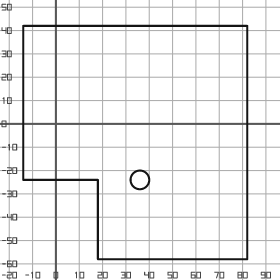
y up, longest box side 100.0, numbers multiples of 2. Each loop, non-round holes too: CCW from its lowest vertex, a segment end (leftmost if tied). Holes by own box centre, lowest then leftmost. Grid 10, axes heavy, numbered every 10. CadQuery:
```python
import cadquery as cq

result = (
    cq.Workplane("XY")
    .moveTo(18.0, -58.0)
    .lineTo(82.0, -58.0)
    .lineTo(82.0, 42.0)
    .lineTo(-14.0, 42.0)
    .lineTo(-14.0, -24.0)
    .lineTo(18.0, -24.0)
    .close()
    .moveTo(36.0, -24.0)
    .circle(4.0)
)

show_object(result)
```